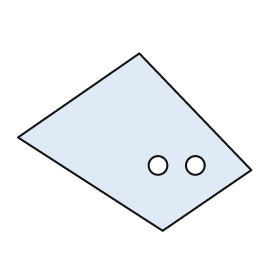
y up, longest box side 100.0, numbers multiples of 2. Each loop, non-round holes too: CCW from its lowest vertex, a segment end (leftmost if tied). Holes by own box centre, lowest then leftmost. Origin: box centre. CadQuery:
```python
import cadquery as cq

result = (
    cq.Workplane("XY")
    .moveTo(12.0, -38.0)
    .lineTo(50.0, -12.0)
    .lineTo(2.0, 38.0)
    .lineTo(-50.0, 2.0)
    .close()
    .moveTo(10.0, -10.0)
    .circle(4.0)
    .moveTo(26.0, -10.0)
    .circle(4.0)
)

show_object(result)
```